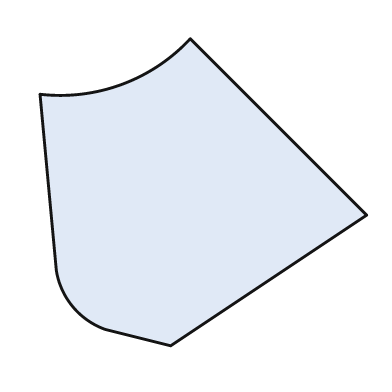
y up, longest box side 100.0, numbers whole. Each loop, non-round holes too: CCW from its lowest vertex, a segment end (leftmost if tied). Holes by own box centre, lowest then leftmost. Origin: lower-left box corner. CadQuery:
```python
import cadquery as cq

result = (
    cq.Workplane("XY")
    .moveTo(40.0, 0.0)
    .lineTo(100.0, 40.0)
    .lineTo(46.0, 94.0)
    .threePointArc((25.0, 80.0), (0.0, 77.0))
    .lineTo(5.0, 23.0)
    .threePointArc((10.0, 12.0), (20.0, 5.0))
    .close()
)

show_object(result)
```